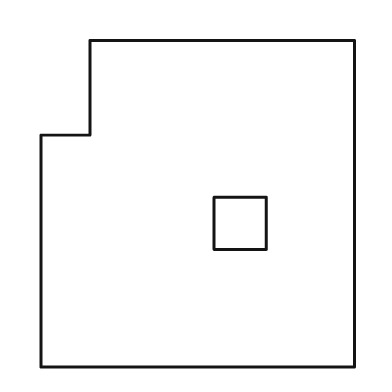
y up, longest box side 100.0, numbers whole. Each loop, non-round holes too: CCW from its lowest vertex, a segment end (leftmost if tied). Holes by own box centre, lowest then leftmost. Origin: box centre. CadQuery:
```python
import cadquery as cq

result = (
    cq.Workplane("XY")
    .moveTo(-48.0, -50.0)
    .lineTo(48.0, -50.0)
    .lineTo(48.0, 50.0)
    .lineTo(-33.0, 50.0)
    .lineTo(-33.0, 21.0)
    .lineTo(-48.0, 21.0)
    .close()
    .moveTo(5.0, -14.0)
    .lineTo(21.0, -14.0)
    .lineTo(21.0, 2.0)
    .lineTo(5.0, 2.0)
    .close()
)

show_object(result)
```